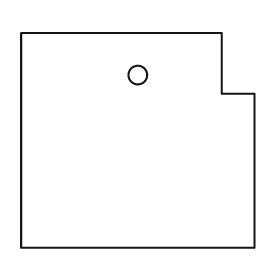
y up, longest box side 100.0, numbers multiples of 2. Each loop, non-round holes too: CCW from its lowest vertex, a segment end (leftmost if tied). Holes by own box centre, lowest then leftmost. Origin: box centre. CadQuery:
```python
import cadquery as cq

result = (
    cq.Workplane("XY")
    .moveTo(-50.0, -46.0)
    .lineTo(50.0, -46.0)
    .lineTo(50.0, 20.0)
    .lineTo(36.0, 20.0)
    .lineTo(36.0, 46.0)
    .lineTo(-50.0, 46.0)
    .close()
    .moveTo(0.0, 28.0)
    .circle(4.0)
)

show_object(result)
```